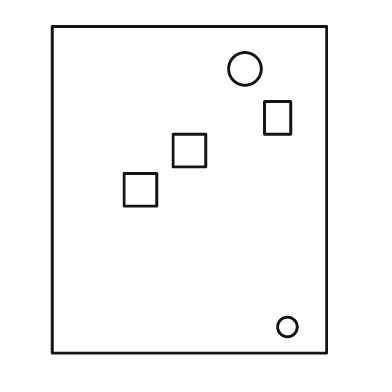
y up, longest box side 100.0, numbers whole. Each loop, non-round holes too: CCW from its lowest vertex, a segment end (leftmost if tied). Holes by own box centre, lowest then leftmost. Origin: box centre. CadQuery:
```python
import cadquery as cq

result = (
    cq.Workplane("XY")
    .moveTo(-42.0, -50.0)
    .lineTo(42.0, -50.0)
    .lineTo(42.0, 50.0)
    .lineTo(-42.0, 50.0)
    .close()
    .moveTo(30.0, -42.0)
    .circle(3.0)
    .moveTo(-20.0, -5.0)
    .lineTo(-10.0, -5.0)
    .lineTo(-10.0, 5.0)
    .lineTo(-20.0, 5.0)
    .close()
    .moveTo(-5.0, 7.0)
    .lineTo(5.0, 7.0)
    .lineTo(5.0, 17.0)
    .lineTo(-5.0, 17.0)
    .close()
    .moveTo(23.0, 17.0)
    .lineTo(31.0, 17.0)
    .lineTo(31.0, 27.0)
    .lineTo(23.0, 27.0)
    .close()
    .moveTo(17.0, 37.0)
    .circle(5.0)
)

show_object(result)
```